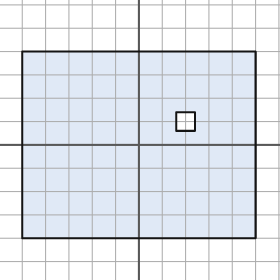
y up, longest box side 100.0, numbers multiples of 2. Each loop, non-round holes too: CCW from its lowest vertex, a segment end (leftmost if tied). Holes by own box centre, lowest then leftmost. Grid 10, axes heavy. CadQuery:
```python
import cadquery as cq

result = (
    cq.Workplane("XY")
    .moveTo(-50.0, -40.0)
    .lineTo(50.0, -40.0)
    .lineTo(50.0, 40.0)
    .lineTo(-50.0, 40.0)
    .close()
    .moveTo(16.0, 6.0)
    .lineTo(24.0, 6.0)
    .lineTo(24.0, 14.0)
    .lineTo(16.0, 14.0)
    .close()
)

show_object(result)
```